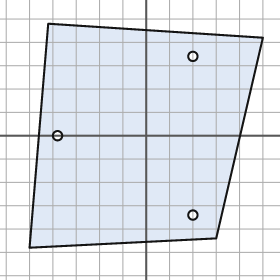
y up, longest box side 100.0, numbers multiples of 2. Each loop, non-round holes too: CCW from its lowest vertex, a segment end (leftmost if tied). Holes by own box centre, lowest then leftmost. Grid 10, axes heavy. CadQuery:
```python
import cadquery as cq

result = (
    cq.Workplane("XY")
    .moveTo(-50.0, -48.0)
    .lineTo(30.0, -44.0)
    .lineTo(50.0, 42.0)
    .lineTo(-42.0, 48.0)
    .close()
    .moveTo(20.0, -34.0)
    .circle(2.0)
    .moveTo(-38.0, 0.0)
    .circle(2.0)
    .moveTo(20.0, 34.0)
    .circle(2.0)
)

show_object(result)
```